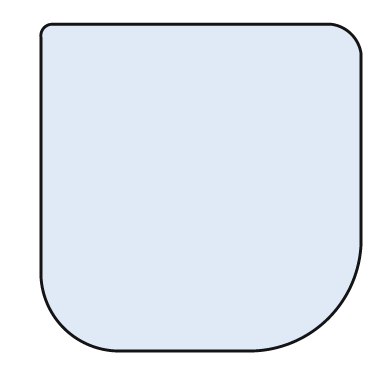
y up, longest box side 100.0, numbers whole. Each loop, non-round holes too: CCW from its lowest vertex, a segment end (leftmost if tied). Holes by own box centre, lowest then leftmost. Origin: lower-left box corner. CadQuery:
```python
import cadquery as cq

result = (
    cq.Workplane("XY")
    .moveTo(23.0, 0.0)
    .lineTo(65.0, 0.0)
    .threePointArc((88.0, 10.0), (98.0, 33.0))
    .lineTo(98.0, 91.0)
    .threePointArc((95.0, 97.0), (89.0, 100.0))
    .lineTo(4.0, 100.0)
    .threePointArc((1.0, 99.0), (0.0, 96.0))
    .lineTo(0.0, 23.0)
    .threePointArc((7.0, 7.0), (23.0, 0.0))
    .close()
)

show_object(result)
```